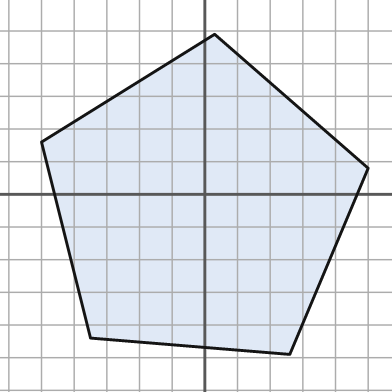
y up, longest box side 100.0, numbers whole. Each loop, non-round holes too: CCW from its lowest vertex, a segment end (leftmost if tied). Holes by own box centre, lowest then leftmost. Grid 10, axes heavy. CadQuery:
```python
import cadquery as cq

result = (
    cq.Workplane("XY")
    .moveTo(26.0, -49.0)
    .lineTo(50.0, 8.0)
    .lineTo(3.0, 49.0)
    .lineTo(-50.0, 16.0)
    .lineTo(-35.0, -44.0)
    .close()
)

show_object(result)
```